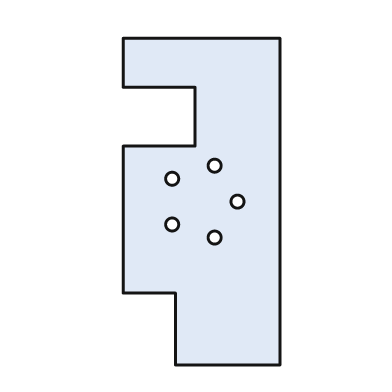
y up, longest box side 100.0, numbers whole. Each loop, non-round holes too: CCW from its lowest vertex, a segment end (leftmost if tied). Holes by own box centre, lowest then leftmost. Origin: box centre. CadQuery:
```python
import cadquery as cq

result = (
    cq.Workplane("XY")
    .moveTo(-8.0, -50.0)
    .lineTo(24.0, -50.0)
    .lineTo(24.0, 50.0)
    .lineTo(-24.0, 50.0)
    .lineTo(-24.0, 35.0)
    .lineTo(-2.0, 35.0)
    .lineTo(-2.0, 17.0)
    .lineTo(-24.0, 17.0)
    .lineTo(-24.0, -28.0)
    .lineTo(-8.0, -28.0)
    .close()
    .moveTo(4.0, -11.0)
    .circle(2.0)
    .moveTo(-9.0, -7.0)
    .circle(2.0)
    .moveTo(11.0, 0.0)
    .circle(2.0)
    .moveTo(-9.0, 7.0)
    .circle(2.0)
    .moveTo(4.0, 11.0)
    .circle(2.0)
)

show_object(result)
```